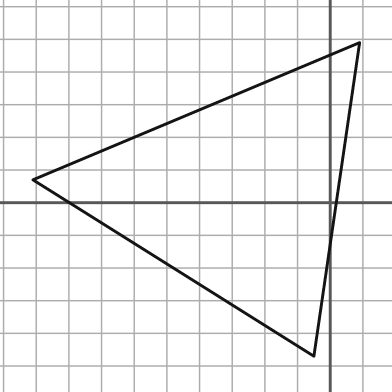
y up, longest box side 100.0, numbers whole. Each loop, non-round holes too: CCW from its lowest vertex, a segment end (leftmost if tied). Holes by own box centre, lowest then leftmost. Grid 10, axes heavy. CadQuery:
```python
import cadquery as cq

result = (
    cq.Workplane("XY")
    .moveTo(-5.0, -47.0)
    .lineTo(9.0, 49.0)
    .lineTo(-91.0, 7.0)
    .close()
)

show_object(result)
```